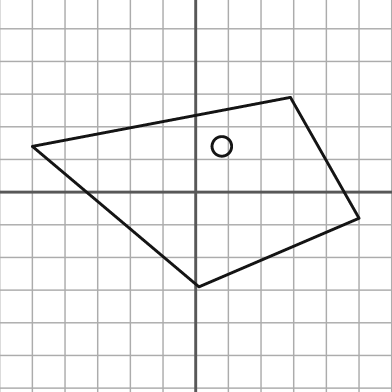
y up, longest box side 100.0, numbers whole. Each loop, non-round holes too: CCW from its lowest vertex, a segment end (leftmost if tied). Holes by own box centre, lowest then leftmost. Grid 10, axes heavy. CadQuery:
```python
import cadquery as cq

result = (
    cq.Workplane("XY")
    .moveTo(1.0, -29.0)
    .lineTo(50.0, -8.0)
    .lineTo(29.0, 29.0)
    .lineTo(-50.0, 14.0)
    .close()
    .moveTo(8.0, 14.0)
    .circle(3.0)
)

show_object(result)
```